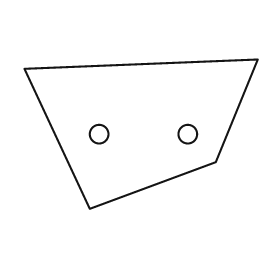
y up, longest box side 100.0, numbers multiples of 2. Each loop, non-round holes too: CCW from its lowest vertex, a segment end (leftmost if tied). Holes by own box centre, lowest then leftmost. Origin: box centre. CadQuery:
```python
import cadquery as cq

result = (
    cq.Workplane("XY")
    .moveTo(-22.0, -32.0)
    .lineTo(32.0, -12.0)
    .lineTo(50.0, 32.0)
    .lineTo(-50.0, 28.0)
    .close()
    .moveTo(-18.0, 0.0)
    .circle(4.0)
    .moveTo(20.0, 0.0)
    .circle(4.0)
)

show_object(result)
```